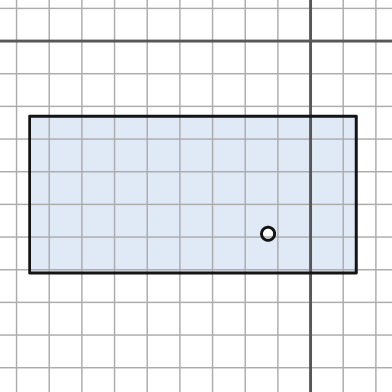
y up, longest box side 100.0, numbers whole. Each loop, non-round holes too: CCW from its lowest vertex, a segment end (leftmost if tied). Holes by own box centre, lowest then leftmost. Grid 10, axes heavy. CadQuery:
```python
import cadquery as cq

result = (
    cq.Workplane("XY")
    .moveTo(-86.0, -71.0)
    .lineTo(14.0, -71.0)
    .lineTo(14.0, -23.0)
    .lineTo(-86.0, -23.0)
    .close()
    .moveTo(-13.0, -59.0)
    .circle(2.0)
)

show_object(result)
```